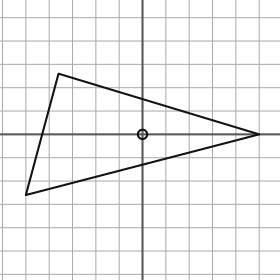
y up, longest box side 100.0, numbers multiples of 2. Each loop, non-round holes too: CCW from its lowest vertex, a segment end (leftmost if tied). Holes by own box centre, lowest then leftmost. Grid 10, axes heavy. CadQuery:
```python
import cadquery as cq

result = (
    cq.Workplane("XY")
    .moveTo(-50.0, -26.0)
    .lineTo(50.0, 0.0)
    .lineTo(-36.0, 26.0)
    .close()
    .moveTo(0.0, 0.0)
    .circle(2.0)
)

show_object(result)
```